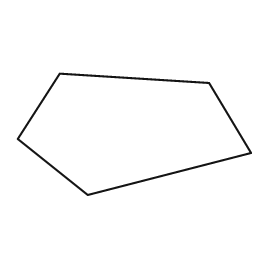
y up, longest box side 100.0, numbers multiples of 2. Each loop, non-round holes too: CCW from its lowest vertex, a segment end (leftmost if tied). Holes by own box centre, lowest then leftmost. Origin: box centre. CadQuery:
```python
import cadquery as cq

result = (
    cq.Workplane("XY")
    .moveTo(-20.0, -26.0)
    .lineTo(50.0, -8.0)
    .lineTo(32.0, 22.0)
    .lineTo(-32.0, 26.0)
    .lineTo(-50.0, -2.0)
    .close()
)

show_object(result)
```